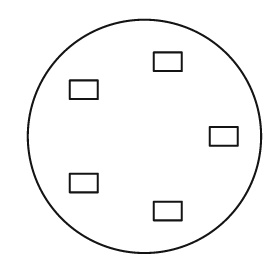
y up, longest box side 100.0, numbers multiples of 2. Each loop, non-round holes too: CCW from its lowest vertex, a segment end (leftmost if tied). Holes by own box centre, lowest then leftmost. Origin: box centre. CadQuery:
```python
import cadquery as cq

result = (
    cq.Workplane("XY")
    .moveTo(0.0, 0.0)
    .circle(50.0)
    .moveTo(4.0, -36.0)
    .lineTo(16.0, -36.0)
    .lineTo(16.0, -28.0)
    .lineTo(4.0, -28.0)
    .close()
    .moveTo(-32.0, -24.0)
    .lineTo(-20.0, -24.0)
    .lineTo(-20.0, -16.0)
    .lineTo(-32.0, -16.0)
    .close()
    .moveTo(28.0, -4.0)
    .lineTo(40.0, -4.0)
    .lineTo(40.0, 4.0)
    .lineTo(28.0, 4.0)
    .close()
    .moveTo(-32.0, 16.0)
    .lineTo(-20.0, 16.0)
    .lineTo(-20.0, 24.0)
    .lineTo(-32.0, 24.0)
    .close()
    .moveTo(4.0, 28.0)
    .lineTo(16.0, 28.0)
    .lineTo(16.0, 36.0)
    .lineTo(4.0, 36.0)
    .close()
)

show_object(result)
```